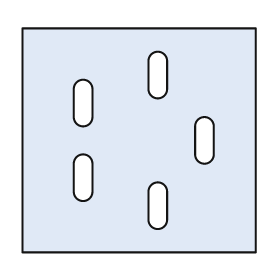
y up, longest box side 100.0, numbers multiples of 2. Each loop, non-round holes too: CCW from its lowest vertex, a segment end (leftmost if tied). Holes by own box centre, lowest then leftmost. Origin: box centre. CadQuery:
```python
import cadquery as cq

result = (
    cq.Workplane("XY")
    .moveTo(-50.0, -48.0)
    .lineTo(50.0, -48.0)
    .lineTo(50.0, 48.0)
    .lineTo(-50.0, 48.0)
    .close()
    .moveTo(4.0, -34.0)
    .threePointArc((8.0, -38.0), (12.0, -34.0))
    .lineTo(12.0, -22.0)
    .threePointArc((8.0, -18.0), (4.0, -22.0))
    .close()
    .moveTo(-28.0, -22.0)
    .threePointArc((-24.0, -26.0), (-20.0, -22.0))
    .lineTo(-20.0, -10.0)
    .threePointArc((-24.0, -6.0), (-28.0, -10.0))
    .close()
    .moveTo(24.0, -6.0)
    .threePointArc((28.0, -10.0), (32.0, -6.0))
    .lineTo(32.0, 6.0)
    .threePointArc((28.0, 10.0), (24.0, 6.0))
    .close()
    .moveTo(-28.0, 10.0)
    .threePointArc((-24.0, 6.0), (-20.0, 10.0))
    .lineTo(-20.0, 22.0)
    .threePointArc((-24.0, 26.0), (-28.0, 22.0))
    .close()
    .moveTo(4.0, 22.0)
    .threePointArc((8.0, 18.0), (12.0, 22.0))
    .lineTo(12.0, 34.0)
    .threePointArc((8.0, 38.0), (4.0, 34.0))
    .close()
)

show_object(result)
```